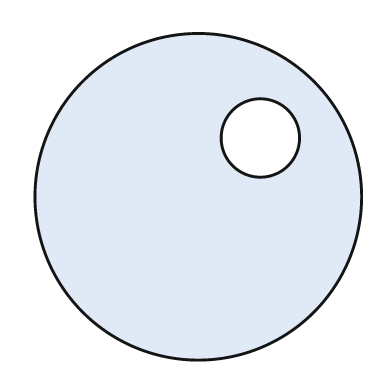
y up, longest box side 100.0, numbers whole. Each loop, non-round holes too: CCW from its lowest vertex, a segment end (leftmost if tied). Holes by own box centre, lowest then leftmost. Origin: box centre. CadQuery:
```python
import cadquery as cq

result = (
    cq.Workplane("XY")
    .moveTo(0.0, 0.0)
    .circle(50.0)
    .moveTo(19.0, 18.0)
    .circle(12.0)
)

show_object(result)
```